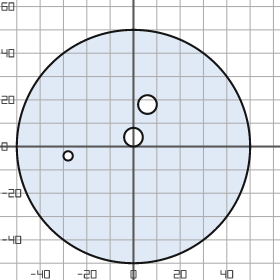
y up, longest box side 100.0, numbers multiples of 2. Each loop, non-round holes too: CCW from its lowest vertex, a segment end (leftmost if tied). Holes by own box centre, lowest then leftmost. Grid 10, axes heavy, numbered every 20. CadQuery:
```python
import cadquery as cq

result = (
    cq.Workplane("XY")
    .moveTo(0.0, 0.0)
    .circle(50.0)
    .moveTo(-28.0, -4.0)
    .circle(2.0)
    .moveTo(0.0, 4.0)
    .circle(4.0)
    .moveTo(6.0, 18.0)
    .circle(4.0)
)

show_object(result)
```